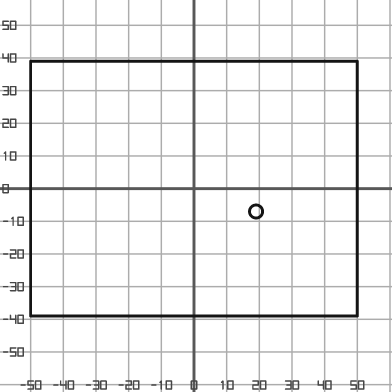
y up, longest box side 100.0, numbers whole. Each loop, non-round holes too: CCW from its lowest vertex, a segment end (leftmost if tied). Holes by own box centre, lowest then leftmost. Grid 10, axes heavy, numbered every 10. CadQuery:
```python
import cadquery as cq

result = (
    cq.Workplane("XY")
    .moveTo(-50.0, -39.0)
    .lineTo(50.0, -39.0)
    .lineTo(50.0, 39.0)
    .lineTo(-50.0, 39.0)
    .close()
    .moveTo(19.0, -7.0)
    .circle(2.0)
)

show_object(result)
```